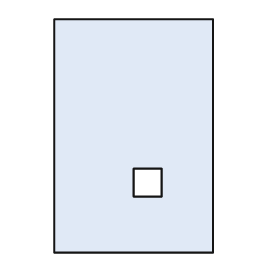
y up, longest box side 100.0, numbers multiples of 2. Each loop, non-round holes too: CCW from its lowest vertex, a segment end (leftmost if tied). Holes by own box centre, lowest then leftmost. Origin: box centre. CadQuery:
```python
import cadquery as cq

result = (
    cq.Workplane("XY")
    .moveTo(-34.0, -50.0)
    .lineTo(34.0, -50.0)
    .lineTo(34.0, 50.0)
    .lineTo(-34.0, 50.0)
    .close()
    .moveTo(0.0, -26.0)
    .lineTo(12.0, -26.0)
    .lineTo(12.0, -14.0)
    .lineTo(0.0, -14.0)
    .close()
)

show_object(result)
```